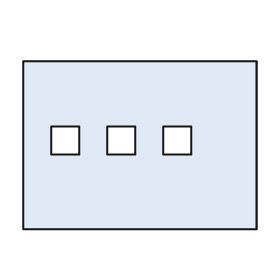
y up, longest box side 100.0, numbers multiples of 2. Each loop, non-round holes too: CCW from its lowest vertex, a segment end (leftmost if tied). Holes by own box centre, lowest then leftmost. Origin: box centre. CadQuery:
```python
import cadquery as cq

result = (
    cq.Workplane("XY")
    .moveTo(-50.0, -36.0)
    .lineTo(50.0, -36.0)
    .lineTo(50.0, 36.0)
    .lineTo(-50.0, 36.0)
    .close()
    .moveTo(-38.0, -4.0)
    .lineTo(-26.0, -4.0)
    .lineTo(-26.0, 8.0)
    .lineTo(-38.0, 8.0)
    .close()
    .moveTo(-14.0, -4.0)
    .lineTo(-2.0, -4.0)
    .lineTo(-2.0, 8.0)
    .lineTo(-14.0, 8.0)
    .close()
    .moveTo(10.0, -4.0)
    .lineTo(22.0, -4.0)
    .lineTo(22.0, 8.0)
    .lineTo(10.0, 8.0)
    .close()
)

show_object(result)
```